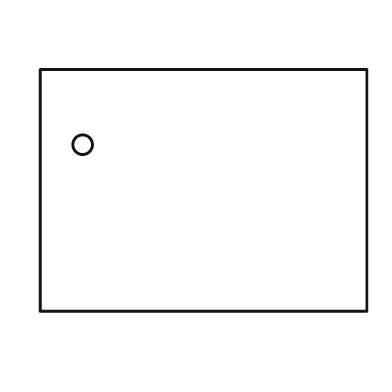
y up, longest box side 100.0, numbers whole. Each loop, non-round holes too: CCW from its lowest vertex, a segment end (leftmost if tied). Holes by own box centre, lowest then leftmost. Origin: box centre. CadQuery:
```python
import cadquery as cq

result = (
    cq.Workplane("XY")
    .moveTo(-50.0, -37.0)
    .lineTo(50.0, -37.0)
    .lineTo(50.0, 37.0)
    .lineTo(-50.0, 37.0)
    .close()
    .moveTo(-37.0, 14.0)
    .circle(3.0)
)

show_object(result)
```